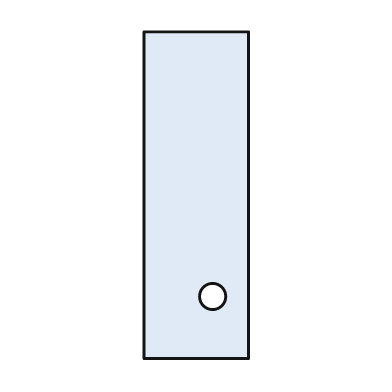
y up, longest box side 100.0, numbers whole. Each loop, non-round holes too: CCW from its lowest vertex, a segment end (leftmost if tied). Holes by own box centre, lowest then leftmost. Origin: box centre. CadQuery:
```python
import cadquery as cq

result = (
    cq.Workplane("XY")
    .moveTo(-16.0, -50.0)
    .lineTo(16.0, -50.0)
    .lineTo(16.0, 50.0)
    .lineTo(-16.0, 50.0)
    .close()
    .moveTo(5.0, -31.0)
    .circle(4.0)
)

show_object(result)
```